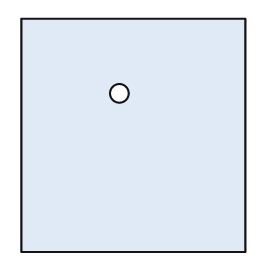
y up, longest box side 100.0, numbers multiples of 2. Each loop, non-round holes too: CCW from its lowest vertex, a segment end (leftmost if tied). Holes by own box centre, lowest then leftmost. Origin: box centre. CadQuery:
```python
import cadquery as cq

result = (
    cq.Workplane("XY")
    .moveTo(-48.0, -50.0)
    .lineTo(48.0, -50.0)
    .lineTo(48.0, 50.0)
    .lineTo(-48.0, 50.0)
    .close()
    .moveTo(-6.0, 18.0)
    .circle(4.0)
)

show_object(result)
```